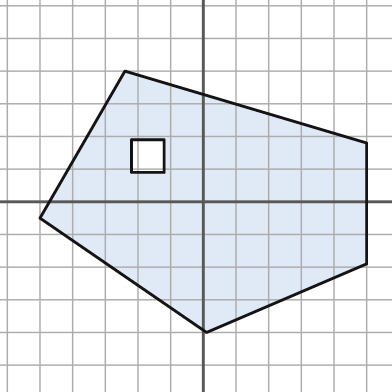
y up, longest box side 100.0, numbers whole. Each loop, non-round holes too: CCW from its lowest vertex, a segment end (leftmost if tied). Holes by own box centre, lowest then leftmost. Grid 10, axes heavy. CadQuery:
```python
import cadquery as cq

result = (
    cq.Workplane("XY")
    .moveTo(1.0, -40.0)
    .lineTo(50.0, -19.0)
    .lineTo(50.0, 18.0)
    .lineTo(-24.0, 40.0)
    .lineTo(-50.0, -5.0)
    .close()
    .moveTo(-22.0, 9.0)
    .lineTo(-12.0, 9.0)
    .lineTo(-12.0, 19.0)
    .lineTo(-22.0, 19.0)
    .close()
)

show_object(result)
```